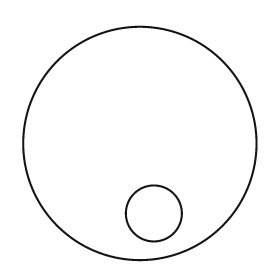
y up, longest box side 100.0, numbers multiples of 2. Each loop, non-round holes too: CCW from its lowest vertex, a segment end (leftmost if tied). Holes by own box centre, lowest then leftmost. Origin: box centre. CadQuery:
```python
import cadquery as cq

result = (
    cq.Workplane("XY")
    .moveTo(0.0, 0.0)
    .circle(50.0)
    .moveTo(6.0, -30.0)
    .circle(12.0)
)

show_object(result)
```